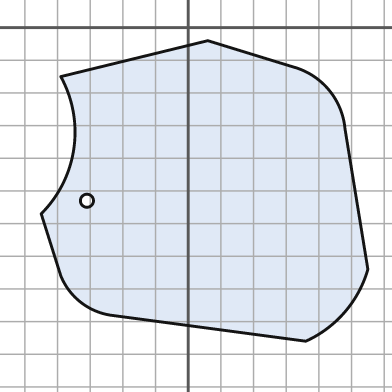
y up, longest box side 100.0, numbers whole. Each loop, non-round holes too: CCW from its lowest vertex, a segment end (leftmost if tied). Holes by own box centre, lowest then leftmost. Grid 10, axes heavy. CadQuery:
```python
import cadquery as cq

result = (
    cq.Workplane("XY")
    .moveTo(36.0, -96.0)
    .threePointArc((48.0, -87.0), (55.0, -74.0))
    .lineTo(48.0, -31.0)
    .threePointArc((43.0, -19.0), (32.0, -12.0))
    .lineTo(6.0, -4.0)
    .lineTo(-39.0, -15.0)
    .threePointArc((-35.0, -37.0), (-45.0, -57.0))
    .lineTo(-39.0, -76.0)
    .threePointArc((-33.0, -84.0), (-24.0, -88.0))
    .close()
    .moveTo(-31.0, -53.0)
    .circle(2.0)
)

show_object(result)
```